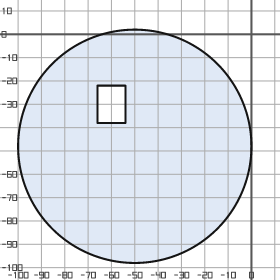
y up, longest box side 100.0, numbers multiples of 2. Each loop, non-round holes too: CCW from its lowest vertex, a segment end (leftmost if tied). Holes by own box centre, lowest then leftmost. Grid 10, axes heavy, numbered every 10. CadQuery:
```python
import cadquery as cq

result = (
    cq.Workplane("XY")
    .moveTo(-50.0, -48.0)
    .circle(50.0)
    .moveTo(-66.0, -38.0)
    .lineTo(-54.0, -38.0)
    .lineTo(-54.0, -22.0)
    .lineTo(-66.0, -22.0)
    .close()
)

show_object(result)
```